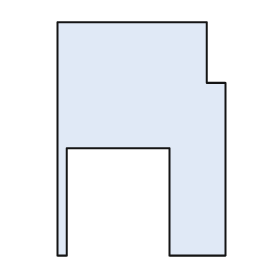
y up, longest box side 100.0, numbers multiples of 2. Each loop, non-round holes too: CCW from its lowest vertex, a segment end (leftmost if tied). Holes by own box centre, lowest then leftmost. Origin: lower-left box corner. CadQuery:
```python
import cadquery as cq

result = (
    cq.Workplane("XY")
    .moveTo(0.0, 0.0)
    .lineTo(4.0, 0.0)
    .lineTo(4.0, 46.0)
    .lineTo(48.0, 46.0)
    .lineTo(48.0, 0.0)
    .lineTo(72.0, 0.0)
    .lineTo(72.0, 74.0)
    .lineTo(64.0, 74.0)
    .lineTo(64.0, 100.0)
    .lineTo(0.0, 100.0)
    .close()
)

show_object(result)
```